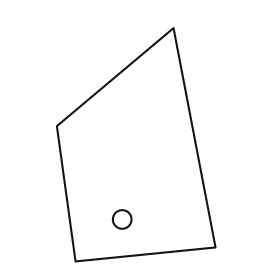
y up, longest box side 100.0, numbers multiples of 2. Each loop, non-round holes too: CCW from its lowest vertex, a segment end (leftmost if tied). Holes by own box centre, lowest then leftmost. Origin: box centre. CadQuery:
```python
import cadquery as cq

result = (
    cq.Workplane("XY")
    .moveTo(-26.0, -50.0)
    .lineTo(34.0, -44.0)
    .lineTo(16.0, 50.0)
    .lineTo(-34.0, 8.0)
    .close()
    .moveTo(-6.0, -32.0)
    .circle(4.0)
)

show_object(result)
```